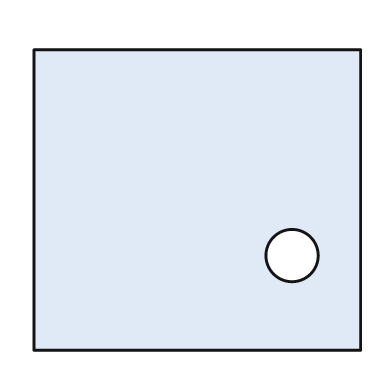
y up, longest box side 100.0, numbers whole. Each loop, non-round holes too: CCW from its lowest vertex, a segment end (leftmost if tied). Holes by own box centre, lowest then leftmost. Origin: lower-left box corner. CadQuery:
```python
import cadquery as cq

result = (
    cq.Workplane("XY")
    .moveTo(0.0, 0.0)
    .lineTo(100.0, 0.0)
    .lineTo(100.0, 92.0)
    .lineTo(0.0, 92.0)
    .close()
    .moveTo(79.0, 29.0)
    .circle(8.0)
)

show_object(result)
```